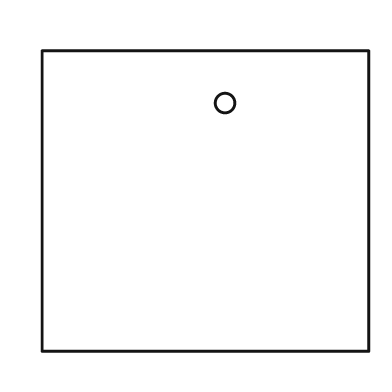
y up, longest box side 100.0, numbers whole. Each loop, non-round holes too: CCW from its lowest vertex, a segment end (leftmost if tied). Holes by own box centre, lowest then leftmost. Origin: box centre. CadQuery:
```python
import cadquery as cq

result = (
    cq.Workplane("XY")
    .moveTo(-50.0, -46.0)
    .lineTo(50.0, -46.0)
    .lineTo(50.0, 46.0)
    .lineTo(-50.0, 46.0)
    .close()
    .moveTo(6.0, 30.0)
    .circle(3.0)
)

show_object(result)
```